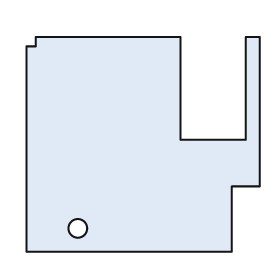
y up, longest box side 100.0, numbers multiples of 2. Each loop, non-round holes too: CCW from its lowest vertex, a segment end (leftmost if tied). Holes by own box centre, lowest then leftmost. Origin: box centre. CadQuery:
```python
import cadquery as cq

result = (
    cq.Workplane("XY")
    .moveTo(-50.0, -46.0)
    .lineTo(38.0, -46.0)
    .lineTo(38.0, -18.0)
    .lineTo(50.0, -18.0)
    .lineTo(50.0, 46.0)
    .lineTo(44.0, 46.0)
    .lineTo(44.0, 2.0)
    .lineTo(16.0, 2.0)
    .lineTo(16.0, 46.0)
    .lineTo(-46.0, 46.0)
    .lineTo(-46.0, 42.0)
    .lineTo(-50.0, 42.0)
    .close()
    .moveTo(-28.0, -36.0)
    .circle(4.0)
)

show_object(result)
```